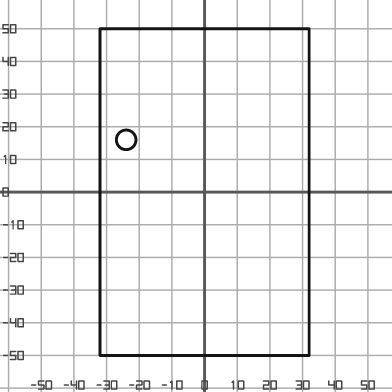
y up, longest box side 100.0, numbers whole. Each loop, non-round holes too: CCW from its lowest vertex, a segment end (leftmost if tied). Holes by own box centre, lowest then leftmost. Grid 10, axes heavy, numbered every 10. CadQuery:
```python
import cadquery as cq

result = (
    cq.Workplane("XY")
    .moveTo(-32.0, -50.0)
    .lineTo(32.0, -50.0)
    .lineTo(32.0, 50.0)
    .lineTo(-32.0, 50.0)
    .close()
    .moveTo(-24.0, 16.0)
    .circle(3.0)
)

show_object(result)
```